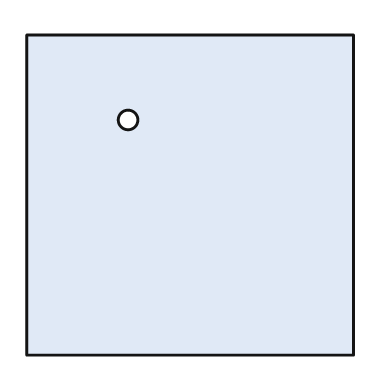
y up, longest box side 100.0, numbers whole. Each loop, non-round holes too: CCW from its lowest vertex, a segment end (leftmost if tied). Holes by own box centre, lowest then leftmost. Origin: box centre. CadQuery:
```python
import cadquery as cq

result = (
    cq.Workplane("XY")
    .moveTo(-50.0, -49.0)
    .lineTo(50.0, -49.0)
    .lineTo(50.0, 49.0)
    .lineTo(-50.0, 49.0)
    .close()
    .moveTo(-19.0, 23.0)
    .circle(3.0)
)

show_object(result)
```